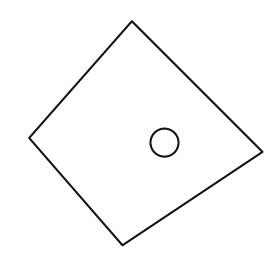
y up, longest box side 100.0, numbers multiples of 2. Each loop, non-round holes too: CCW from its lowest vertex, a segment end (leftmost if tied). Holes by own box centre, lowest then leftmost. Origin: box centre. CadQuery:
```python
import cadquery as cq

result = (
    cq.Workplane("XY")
    .moveTo(-10.0, -48.0)
    .lineTo(50.0, -8.0)
    .lineTo(-6.0, 48.0)
    .lineTo(-50.0, -2.0)
    .close()
    .moveTo(8.0, -4.0)
    .circle(6.0)
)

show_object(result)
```